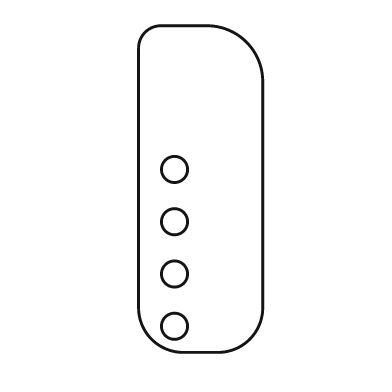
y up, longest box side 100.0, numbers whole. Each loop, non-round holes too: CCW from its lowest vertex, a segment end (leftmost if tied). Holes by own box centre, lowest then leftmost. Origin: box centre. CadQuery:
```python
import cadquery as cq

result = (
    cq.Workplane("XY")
    .moveTo(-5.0, -50.0)
    .lineTo(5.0, -50.0)
    .threePointArc((15.0, -46.0), (19.0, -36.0))
    .lineTo(19.0, 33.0)
    .threePointArc((14.0, 45.0), (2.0, 50.0))
    .lineTo(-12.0, 50.0)
    .threePointArc((-17.0, 48.0), (-19.0, 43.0))
    .lineTo(-19.0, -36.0)
    .threePointArc((-15.0, -46.0), (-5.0, -50.0))
    .close()
    .moveTo(-8.0, -42.0)
    .circle(4.0)
    .moveTo(-8.0, -26.0)
    .circle(4.0)
    .moveTo(-8.0, -10.0)
    .circle(4.0)
    .moveTo(-8.0, 6.0)
    .circle(4.0)
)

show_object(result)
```